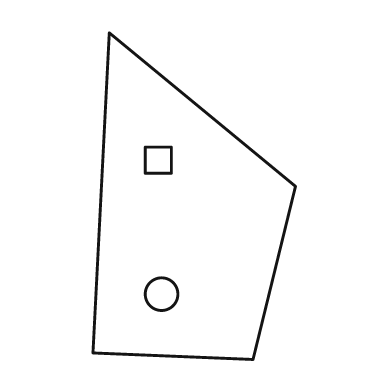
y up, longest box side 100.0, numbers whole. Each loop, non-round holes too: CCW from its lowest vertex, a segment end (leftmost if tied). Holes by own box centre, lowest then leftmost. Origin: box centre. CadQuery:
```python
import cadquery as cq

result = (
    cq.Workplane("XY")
    .moveTo(18.0, -50.0)
    .lineTo(31.0, 3.0)
    .lineTo(-26.0, 50.0)
    .lineTo(-31.0, -48.0)
    .close()
    .moveTo(-10.0, -30.0)
    .circle(5.0)
    .moveTo(-15.0, 7.0)
    .lineTo(-7.0, 7.0)
    .lineTo(-7.0, 15.0)
    .lineTo(-15.0, 15.0)
    .close()
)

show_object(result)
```